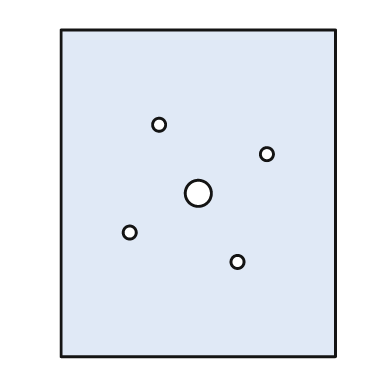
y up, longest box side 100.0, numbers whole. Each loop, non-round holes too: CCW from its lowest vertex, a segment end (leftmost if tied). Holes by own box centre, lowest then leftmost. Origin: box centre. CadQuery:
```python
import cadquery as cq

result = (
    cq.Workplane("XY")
    .moveTo(-42.0, -50.0)
    .lineTo(42.0, -50.0)
    .lineTo(42.0, 50.0)
    .lineTo(-42.0, 50.0)
    .close()
    .moveTo(12.0, -21.0)
    .circle(2.0)
    .moveTo(-21.0, -12.0)
    .circle(2.0)
    .moveTo(0.0, 0.0)
    .circle(4.0)
    .moveTo(21.0, 12.0)
    .circle(2.0)
    .moveTo(-12.0, 21.0)
    .circle(2.0)
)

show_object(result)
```